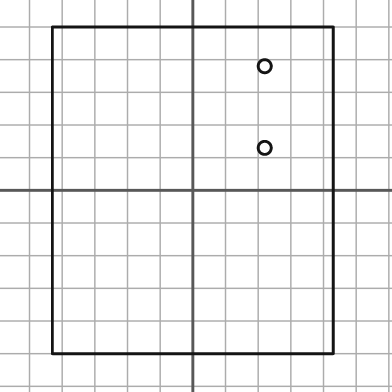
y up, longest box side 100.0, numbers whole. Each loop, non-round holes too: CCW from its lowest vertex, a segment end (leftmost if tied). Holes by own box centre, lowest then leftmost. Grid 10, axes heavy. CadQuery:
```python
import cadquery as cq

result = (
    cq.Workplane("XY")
    .moveTo(-43.0, -50.0)
    .lineTo(43.0, -50.0)
    .lineTo(43.0, 50.0)
    .lineTo(-43.0, 50.0)
    .close()
    .moveTo(22.0, 13.0)
    .circle(2.0)
    .moveTo(22.0, 38.0)
    .circle(2.0)
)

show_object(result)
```